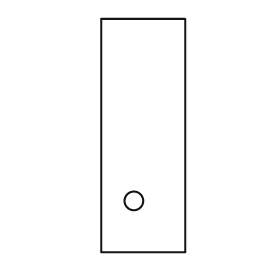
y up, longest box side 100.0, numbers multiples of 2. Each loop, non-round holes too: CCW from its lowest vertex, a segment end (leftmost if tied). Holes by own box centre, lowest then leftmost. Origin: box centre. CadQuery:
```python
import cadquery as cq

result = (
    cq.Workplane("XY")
    .moveTo(-18.0, -50.0)
    .lineTo(18.0, -50.0)
    .lineTo(18.0, 50.0)
    .lineTo(-18.0, 50.0)
    .close()
    .moveTo(-4.0, -28.0)
    .circle(4.0)
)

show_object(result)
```